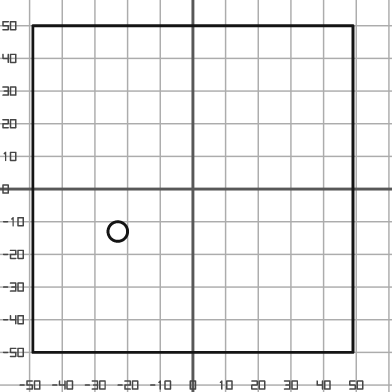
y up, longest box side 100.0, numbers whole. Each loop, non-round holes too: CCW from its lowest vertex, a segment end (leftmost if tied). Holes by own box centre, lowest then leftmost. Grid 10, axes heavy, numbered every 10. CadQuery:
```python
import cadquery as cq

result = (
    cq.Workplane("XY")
    .moveTo(-49.0, -50.0)
    .lineTo(49.0, -50.0)
    .lineTo(49.0, 50.0)
    .lineTo(-49.0, 50.0)
    .close()
    .moveTo(-23.0, -13.0)
    .circle(3.0)
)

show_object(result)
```